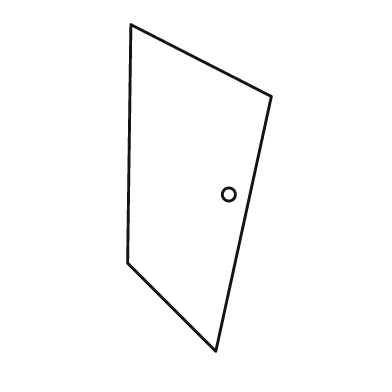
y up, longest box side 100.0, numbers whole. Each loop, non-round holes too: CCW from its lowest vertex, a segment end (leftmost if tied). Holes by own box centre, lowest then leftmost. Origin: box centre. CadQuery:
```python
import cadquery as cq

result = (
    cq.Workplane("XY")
    .moveTo(5.0, -50.0)
    .lineTo(22.0, 28.0)
    .lineTo(-21.0, 50.0)
    .lineTo(-22.0, -23.0)
    .close()
    .moveTo(9.0, -2.0)
    .circle(2.0)
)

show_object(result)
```